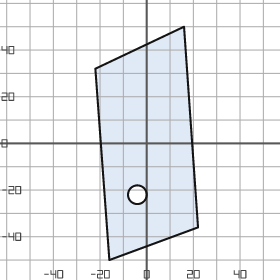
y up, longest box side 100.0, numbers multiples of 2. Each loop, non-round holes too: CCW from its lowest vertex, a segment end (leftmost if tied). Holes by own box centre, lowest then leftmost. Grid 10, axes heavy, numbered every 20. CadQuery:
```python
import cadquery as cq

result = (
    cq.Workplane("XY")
    .moveTo(-16.0, -50.0)
    .lineTo(22.0, -36.0)
    .lineTo(16.0, 50.0)
    .lineTo(-22.0, 32.0)
    .close()
    .moveTo(-4.0, -22.0)
    .circle(4.0)
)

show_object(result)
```